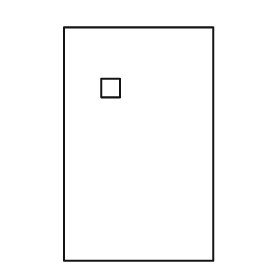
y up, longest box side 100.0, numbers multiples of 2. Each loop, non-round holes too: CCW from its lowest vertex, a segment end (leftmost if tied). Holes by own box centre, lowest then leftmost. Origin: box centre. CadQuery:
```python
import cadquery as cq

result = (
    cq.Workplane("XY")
    .moveTo(-32.0, -50.0)
    .lineTo(32.0, -50.0)
    .lineTo(32.0, 50.0)
    .lineTo(-32.0, 50.0)
    .close()
    .moveTo(-16.0, 20.0)
    .lineTo(-8.0, 20.0)
    .lineTo(-8.0, 28.0)
    .lineTo(-16.0, 28.0)
    .close()
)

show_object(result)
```